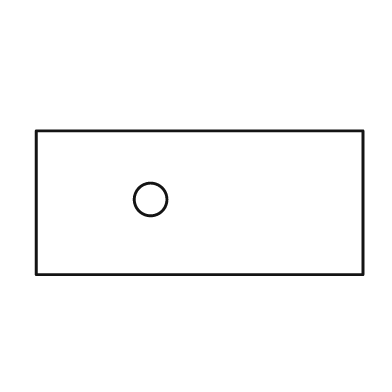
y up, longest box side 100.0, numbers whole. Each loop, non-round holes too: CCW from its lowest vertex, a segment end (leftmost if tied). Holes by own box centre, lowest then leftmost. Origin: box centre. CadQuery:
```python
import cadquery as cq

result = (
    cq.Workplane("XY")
    .moveTo(-50.0, -22.0)
    .lineTo(50.0, -22.0)
    .lineTo(50.0, 22.0)
    .lineTo(-50.0, 22.0)
    .close()
    .moveTo(-15.0, 1.0)
    .circle(5.0)
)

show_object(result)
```